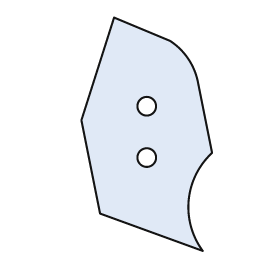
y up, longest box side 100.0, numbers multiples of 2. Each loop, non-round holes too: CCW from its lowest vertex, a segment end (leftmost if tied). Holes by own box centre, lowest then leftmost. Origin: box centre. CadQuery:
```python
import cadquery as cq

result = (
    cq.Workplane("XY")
    .moveTo(24.0, -50.0)
    .threePointArc((18.0, -28.0), (28.0, -8.0))
    .lineTo(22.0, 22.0)
    .threePointArc((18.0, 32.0), (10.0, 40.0))
    .lineTo(-14.0, 50.0)
    .lineTo(-28.0, 6.0)
    .lineTo(-20.0, -34.0)
    .close()
    .moveTo(0.0, -10.0)
    .circle(4.0)
    .moveTo(0.0, 12.0)
    .circle(4.0)
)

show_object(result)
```